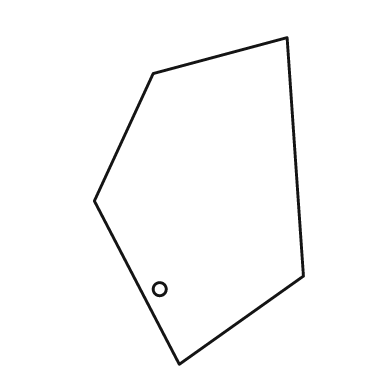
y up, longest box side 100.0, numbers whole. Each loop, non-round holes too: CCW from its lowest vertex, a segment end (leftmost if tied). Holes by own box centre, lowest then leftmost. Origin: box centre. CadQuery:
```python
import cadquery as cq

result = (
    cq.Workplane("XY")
    .moveTo(-6.0, -50.0)
    .lineTo(32.0, -23.0)
    .lineTo(27.0, 50.0)
    .lineTo(-14.0, 39.0)
    .lineTo(-32.0, 0.0)
    .close()
    .moveTo(-12.0, -27.0)
    .circle(2.0)
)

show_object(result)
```